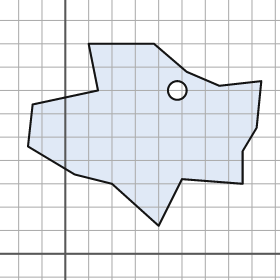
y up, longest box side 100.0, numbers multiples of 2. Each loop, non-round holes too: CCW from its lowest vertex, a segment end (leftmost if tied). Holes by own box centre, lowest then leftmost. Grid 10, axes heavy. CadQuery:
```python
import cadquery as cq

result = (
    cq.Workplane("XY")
    .moveTo(40.0, 12.0)
    .lineTo(50.0, 32.0)
    .lineTo(76.0, 30.0)
    .lineTo(76.0, 44.0)
    .lineTo(82.0, 54.0)
    .lineTo(84.0, 74.0)
    .lineTo(66.0, 72.0)
    .lineTo(52.0, 78.0)
    .lineTo(38.0, 90.0)
    .lineTo(10.0, 90.0)
    .lineTo(14.0, 70.0)
    .lineTo(-14.0, 64.0)
    .lineTo(-16.0, 46.0)
    .lineTo(4.0, 34.0)
    .lineTo(20.0, 30.0)
    .close()
    .moveTo(48.0, 70.0)
    .circle(4.0)
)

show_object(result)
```